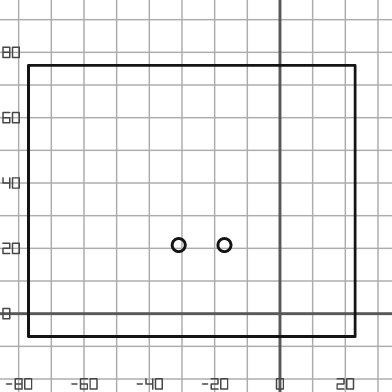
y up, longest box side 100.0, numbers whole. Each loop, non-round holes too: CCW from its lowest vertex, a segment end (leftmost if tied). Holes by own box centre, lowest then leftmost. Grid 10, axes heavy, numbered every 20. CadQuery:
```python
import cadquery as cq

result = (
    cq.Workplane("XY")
    .moveTo(-77.0, -7.0)
    .lineTo(23.0, -7.0)
    .lineTo(23.0, 76.0)
    .lineTo(-77.0, 76.0)
    .close()
    .moveTo(-31.0, 21.0)
    .circle(2.0)
    .moveTo(-17.0, 21.0)
    .circle(2.0)
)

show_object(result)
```